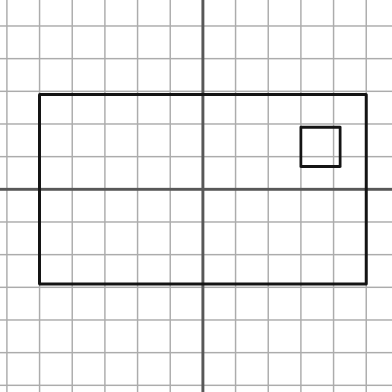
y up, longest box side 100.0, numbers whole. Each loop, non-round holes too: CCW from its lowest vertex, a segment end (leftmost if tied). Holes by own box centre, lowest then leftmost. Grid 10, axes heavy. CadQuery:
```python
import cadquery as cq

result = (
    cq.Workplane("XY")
    .moveTo(-50.0, -29.0)
    .lineTo(50.0, -29.0)
    .lineTo(50.0, 29.0)
    .lineTo(-50.0, 29.0)
    .close()
    .moveTo(30.0, 7.0)
    .lineTo(42.0, 7.0)
    .lineTo(42.0, 19.0)
    .lineTo(30.0, 19.0)
    .close()
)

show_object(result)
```